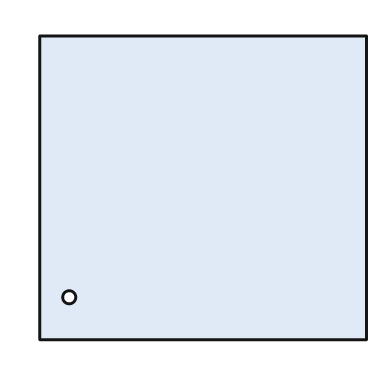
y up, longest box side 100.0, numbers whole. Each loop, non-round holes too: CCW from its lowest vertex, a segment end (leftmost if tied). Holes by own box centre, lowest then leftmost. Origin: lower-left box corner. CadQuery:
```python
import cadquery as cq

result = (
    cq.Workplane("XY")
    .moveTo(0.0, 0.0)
    .lineTo(100.0, 0.0)
    .lineTo(100.0, 93.0)
    .lineTo(0.0, 93.0)
    .close()
    .moveTo(9.0, 13.0)
    .circle(2.0)
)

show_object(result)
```